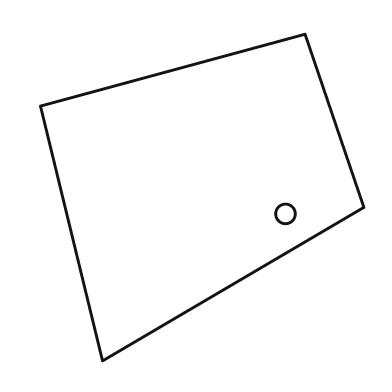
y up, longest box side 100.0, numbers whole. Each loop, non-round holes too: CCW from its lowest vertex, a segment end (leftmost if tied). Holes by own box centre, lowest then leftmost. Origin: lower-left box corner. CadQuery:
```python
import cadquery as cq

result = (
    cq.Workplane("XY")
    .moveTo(19.0, 0.0)
    .lineTo(99.0, 47.0)
    .lineTo(81.0, 100.0)
    .lineTo(0.0, 78.0)
    .close()
    .moveTo(75.0, 45.0)
    .circle(3.0)
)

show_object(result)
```